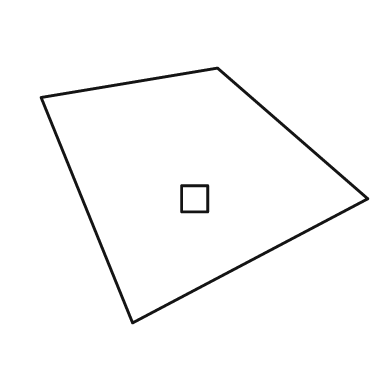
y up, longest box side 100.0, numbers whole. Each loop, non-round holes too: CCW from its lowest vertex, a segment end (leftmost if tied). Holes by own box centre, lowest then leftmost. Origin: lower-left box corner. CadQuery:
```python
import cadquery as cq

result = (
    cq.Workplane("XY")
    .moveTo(28.0, 0.0)
    .lineTo(100.0, 38.0)
    .lineTo(54.0, 78.0)
    .lineTo(0.0, 69.0)
    .close()
    .moveTo(43.0, 34.0)
    .lineTo(51.0, 34.0)
    .lineTo(51.0, 42.0)
    .lineTo(43.0, 42.0)
    .close()
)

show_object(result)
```